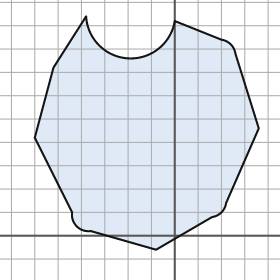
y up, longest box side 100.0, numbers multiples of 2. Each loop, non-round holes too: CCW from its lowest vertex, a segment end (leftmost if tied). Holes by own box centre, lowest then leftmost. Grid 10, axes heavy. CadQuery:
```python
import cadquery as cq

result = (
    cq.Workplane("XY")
    .moveTo(-8.0, -6.0)
    .lineTo(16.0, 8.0)
    .threePointArc((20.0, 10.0), (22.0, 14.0))
    .lineTo(36.0, 46.0)
    .lineTo(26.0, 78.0)
    .threePointArc((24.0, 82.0), (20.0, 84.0))
    .lineTo(0.0, 92.0)
    .threePointArc((-20.0, 76.0), (-38.0, 94.0))
    .lineTo(-52.0, 72.0)
    .lineTo(-60.0, 42.0)
    .lineTo(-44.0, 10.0)
    .threePointArc((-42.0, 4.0), (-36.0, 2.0))
    .close()
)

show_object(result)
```